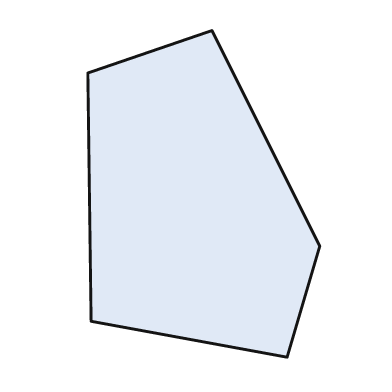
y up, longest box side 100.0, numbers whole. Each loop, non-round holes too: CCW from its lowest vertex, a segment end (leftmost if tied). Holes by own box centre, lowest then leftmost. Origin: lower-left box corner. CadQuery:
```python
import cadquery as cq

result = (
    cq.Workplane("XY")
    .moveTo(61.0, 0.0)
    .lineTo(71.0, 34.0)
    .lineTo(38.0, 100.0)
    .lineTo(0.0, 87.0)
    .lineTo(1.0, 11.0)
    .close()
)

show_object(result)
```